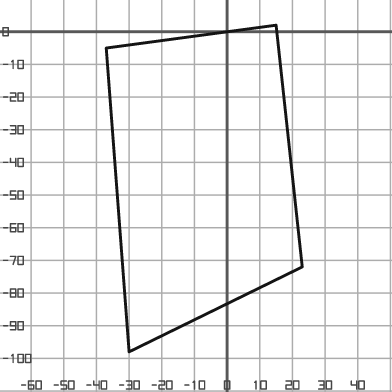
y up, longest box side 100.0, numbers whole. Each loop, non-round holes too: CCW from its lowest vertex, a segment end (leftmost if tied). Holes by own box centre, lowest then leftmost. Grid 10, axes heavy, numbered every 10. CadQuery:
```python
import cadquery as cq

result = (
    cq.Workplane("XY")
    .moveTo(-30.0, -98.0)
    .lineTo(23.0, -72.0)
    .lineTo(15.0, 2.0)
    .lineTo(-37.0, -5.0)
    .close()
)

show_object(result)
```